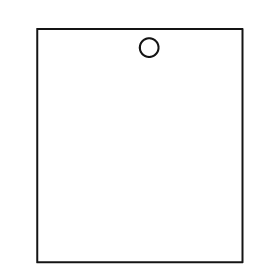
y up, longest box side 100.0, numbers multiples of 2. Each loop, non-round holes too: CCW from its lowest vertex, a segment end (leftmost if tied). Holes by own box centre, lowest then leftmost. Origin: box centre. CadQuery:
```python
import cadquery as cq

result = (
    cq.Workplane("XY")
    .moveTo(-44.0, -50.0)
    .lineTo(44.0, -50.0)
    .lineTo(44.0, 50.0)
    .lineTo(-44.0, 50.0)
    .close()
    .moveTo(4.0, 42.0)
    .circle(4.0)
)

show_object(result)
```